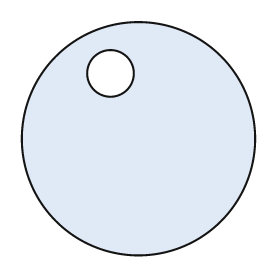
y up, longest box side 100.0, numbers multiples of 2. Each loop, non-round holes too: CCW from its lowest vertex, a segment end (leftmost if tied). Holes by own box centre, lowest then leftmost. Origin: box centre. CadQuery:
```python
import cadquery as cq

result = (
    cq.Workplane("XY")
    .moveTo(0.0, 0.0)
    .circle(50.0)
    .moveTo(-12.0, 28.0)
    .circle(10.0)
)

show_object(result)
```